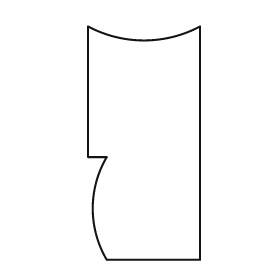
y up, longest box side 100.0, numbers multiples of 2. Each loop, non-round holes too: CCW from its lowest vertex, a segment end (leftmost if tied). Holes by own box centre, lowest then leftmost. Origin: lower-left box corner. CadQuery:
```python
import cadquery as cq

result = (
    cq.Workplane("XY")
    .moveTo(8.0, 0.0)
    .lineTo(48.0, 0.0)
    .lineTo(48.0, 100.0)
    .threePointArc((24.0, 94.0), (0.0, 100.0))
    .lineTo(0.0, 44.0)
    .lineTo(8.0, 44.0)
    .threePointArc((2.0, 22.0), (8.0, 0.0))
    .close()
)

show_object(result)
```